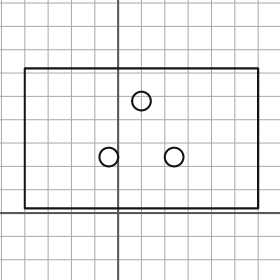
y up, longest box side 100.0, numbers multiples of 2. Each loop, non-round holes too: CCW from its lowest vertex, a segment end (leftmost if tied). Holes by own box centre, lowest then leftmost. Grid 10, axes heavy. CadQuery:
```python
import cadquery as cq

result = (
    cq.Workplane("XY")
    .moveTo(-40.0, 2.0)
    .lineTo(60.0, 2.0)
    .lineTo(60.0, 62.0)
    .lineTo(-40.0, 62.0)
    .close()
    .moveTo(-4.0, 24.0)
    .circle(4.0)
    .moveTo(24.0, 24.0)
    .circle(4.0)
    .moveTo(10.0, 48.0)
    .circle(4.0)
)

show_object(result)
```